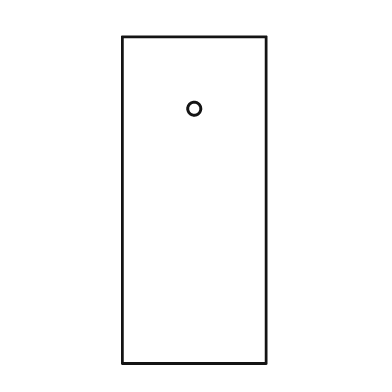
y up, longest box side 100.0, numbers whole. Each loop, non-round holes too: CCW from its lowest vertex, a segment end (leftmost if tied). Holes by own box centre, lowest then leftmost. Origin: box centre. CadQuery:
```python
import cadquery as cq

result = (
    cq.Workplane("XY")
    .moveTo(-22.0, -50.0)
    .lineTo(22.0, -50.0)
    .lineTo(22.0, 50.0)
    .lineTo(-22.0, 50.0)
    .close()
    .moveTo(0.0, 28.0)
    .circle(2.0)
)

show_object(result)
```